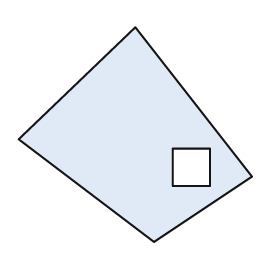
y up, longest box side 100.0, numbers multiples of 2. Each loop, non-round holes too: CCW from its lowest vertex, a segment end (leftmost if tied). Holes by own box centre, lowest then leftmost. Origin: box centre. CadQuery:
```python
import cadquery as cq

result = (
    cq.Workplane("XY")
    .moveTo(8.0, -46.0)
    .lineTo(50.0, -18.0)
    .lineTo(0.0, 46.0)
    .lineTo(-50.0, -2.0)
    .close()
    .moveTo(16.0, -22.0)
    .lineTo(32.0, -22.0)
    .lineTo(32.0, -6.0)
    .lineTo(16.0, -6.0)
    .close()
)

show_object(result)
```